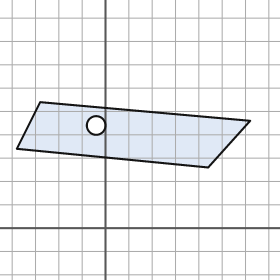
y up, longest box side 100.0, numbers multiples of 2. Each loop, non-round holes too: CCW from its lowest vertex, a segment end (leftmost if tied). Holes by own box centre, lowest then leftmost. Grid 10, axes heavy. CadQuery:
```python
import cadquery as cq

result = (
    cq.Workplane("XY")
    .moveTo(44.0, 26.0)
    .lineTo(62.0, 46.0)
    .lineTo(-28.0, 54.0)
    .lineTo(-38.0, 34.0)
    .close()
    .moveTo(-4.0, 44.0)
    .circle(4.0)
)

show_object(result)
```